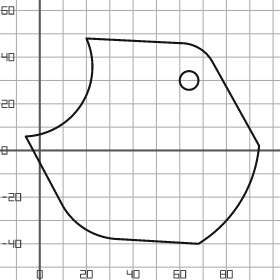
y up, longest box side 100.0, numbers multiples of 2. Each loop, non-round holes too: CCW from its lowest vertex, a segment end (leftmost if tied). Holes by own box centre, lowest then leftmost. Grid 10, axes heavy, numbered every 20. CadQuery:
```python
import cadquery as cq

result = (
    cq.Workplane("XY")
    .moveTo(68.0, -40.0)
    .threePointArc((86.0, -22.0), (94.0, 2.0))
    .lineTo(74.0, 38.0)
    .threePointArc((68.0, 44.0), (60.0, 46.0))
    .lineTo(20.0, 48.0)
    .threePointArc((18.0, 20.0), (-6.0, 6.0))
    .lineTo(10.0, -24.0)
    .threePointArc((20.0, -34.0), (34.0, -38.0))
    .close()
    .moveTo(64.0, 30.0)
    .circle(4.0)
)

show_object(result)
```